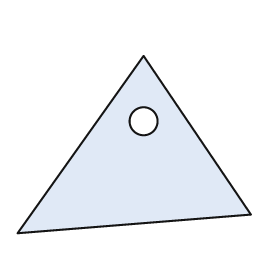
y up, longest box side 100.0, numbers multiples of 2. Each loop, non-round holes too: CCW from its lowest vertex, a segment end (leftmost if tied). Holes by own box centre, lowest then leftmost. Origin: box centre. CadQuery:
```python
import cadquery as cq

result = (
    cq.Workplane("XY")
    .moveTo(-50.0, -38.0)
    .lineTo(50.0, -30.0)
    .lineTo(4.0, 38.0)
    .close()
    .moveTo(4.0, 10.0)
    .circle(6.0)
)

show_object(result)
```